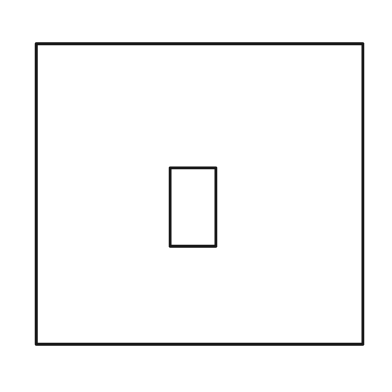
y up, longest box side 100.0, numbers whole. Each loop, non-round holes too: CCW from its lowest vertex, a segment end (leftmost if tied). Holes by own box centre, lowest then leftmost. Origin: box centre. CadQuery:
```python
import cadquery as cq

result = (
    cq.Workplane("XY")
    .moveTo(-50.0, -46.0)
    .lineTo(50.0, -46.0)
    .lineTo(50.0, 46.0)
    .lineTo(-50.0, 46.0)
    .close()
    .moveTo(-9.0, -16.0)
    .lineTo(5.0, -16.0)
    .lineTo(5.0, 8.0)
    .lineTo(-9.0, 8.0)
    .close()
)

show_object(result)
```